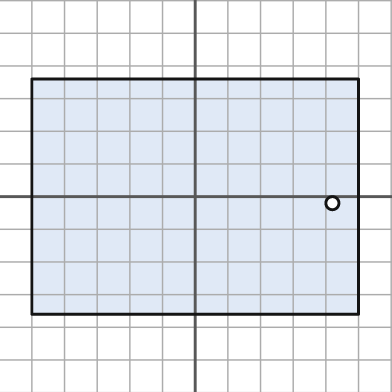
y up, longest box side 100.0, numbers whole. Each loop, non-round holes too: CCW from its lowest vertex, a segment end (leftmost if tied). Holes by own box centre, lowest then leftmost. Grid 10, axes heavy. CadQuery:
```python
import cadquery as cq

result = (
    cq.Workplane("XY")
    .moveTo(-50.0, -36.0)
    .lineTo(50.0, -36.0)
    .lineTo(50.0, 36.0)
    .lineTo(-50.0, 36.0)
    .close()
    .moveTo(42.0, -2.0)
    .circle(2.0)
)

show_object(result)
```